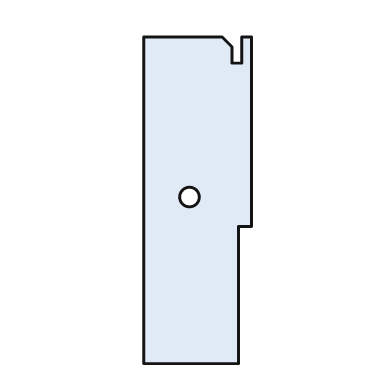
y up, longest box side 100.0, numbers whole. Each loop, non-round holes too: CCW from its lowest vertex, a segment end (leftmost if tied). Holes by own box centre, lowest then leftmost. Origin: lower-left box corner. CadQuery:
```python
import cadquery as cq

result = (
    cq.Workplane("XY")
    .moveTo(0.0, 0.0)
    .lineTo(29.0, 0.0)
    .lineTo(29.0, 42.0)
    .lineTo(33.0, 42.0)
    .lineTo(33.0, 100.0)
    .lineTo(30.0, 100.0)
    .lineTo(30.0, 92.0)
    .lineTo(27.0, 92.0)
    .lineTo(27.0, 97.0)
    .lineTo(24.0, 100.0)
    .lineTo(0.0, 100.0)
    .close()
    .moveTo(14.0, 51.0)
    .circle(3.0)
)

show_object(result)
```